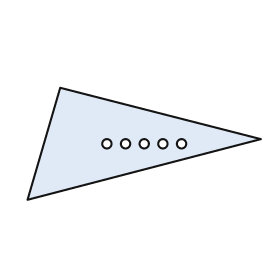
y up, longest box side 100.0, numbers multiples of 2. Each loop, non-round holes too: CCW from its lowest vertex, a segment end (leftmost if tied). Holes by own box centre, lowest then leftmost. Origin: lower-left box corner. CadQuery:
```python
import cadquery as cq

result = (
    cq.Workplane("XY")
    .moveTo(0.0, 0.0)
    .lineTo(100.0, 26.0)
    .lineTo(14.0, 48.0)
    .close()
    .moveTo(34.0, 24.0)
    .circle(2.0)
    .moveTo(42.0, 24.0)
    .circle(2.0)
    .moveTo(50.0, 24.0)
    .circle(2.0)
    .moveTo(58.0, 24.0)
    .circle(2.0)
    .moveTo(66.0, 24.0)
    .circle(2.0)
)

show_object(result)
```